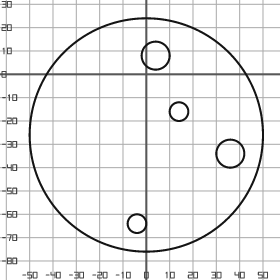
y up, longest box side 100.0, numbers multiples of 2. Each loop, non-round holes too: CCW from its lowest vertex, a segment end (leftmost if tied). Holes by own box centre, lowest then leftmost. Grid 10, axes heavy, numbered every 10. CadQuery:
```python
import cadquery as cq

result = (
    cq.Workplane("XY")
    .moveTo(0.0, -26.0)
    .circle(50.0)
    .moveTo(-4.0, -64.0)
    .circle(4.0)
    .moveTo(36.0, -34.0)
    .circle(6.0)
    .moveTo(14.0, -16.0)
    .circle(4.0)
    .moveTo(4.0, 8.0)
    .circle(6.0)
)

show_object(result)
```